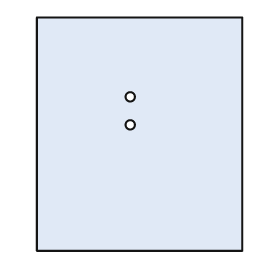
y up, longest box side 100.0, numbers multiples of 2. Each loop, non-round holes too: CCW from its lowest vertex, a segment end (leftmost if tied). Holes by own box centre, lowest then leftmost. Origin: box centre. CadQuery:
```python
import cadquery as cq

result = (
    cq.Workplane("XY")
    .moveTo(-44.0, -50.0)
    .lineTo(44.0, -50.0)
    .lineTo(44.0, 50.0)
    .lineTo(-44.0, 50.0)
    .close()
    .moveTo(-4.0, 4.0)
    .circle(2.0)
    .moveTo(-4.0, 16.0)
    .circle(2.0)
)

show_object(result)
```